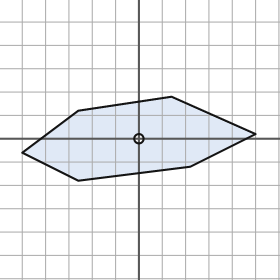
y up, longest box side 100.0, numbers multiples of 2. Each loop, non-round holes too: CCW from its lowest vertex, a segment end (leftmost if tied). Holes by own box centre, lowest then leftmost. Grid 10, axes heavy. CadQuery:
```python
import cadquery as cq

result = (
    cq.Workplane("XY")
    .moveTo(-26.0, -18.0)
    .lineTo(22.0, -12.0)
    .lineTo(50.0, 2.0)
    .lineTo(14.0, 18.0)
    .lineTo(-26.0, 12.0)
    .lineTo(-50.0, -6.0)
    .close()
    .moveTo(0.0, 0.0)
    .circle(2.0)
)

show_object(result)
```